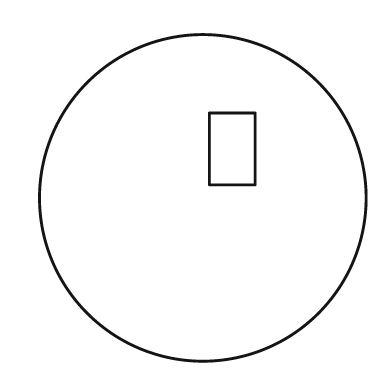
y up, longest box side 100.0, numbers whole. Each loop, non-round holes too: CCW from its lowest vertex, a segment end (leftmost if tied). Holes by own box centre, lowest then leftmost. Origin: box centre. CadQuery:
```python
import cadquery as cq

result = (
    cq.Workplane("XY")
    .moveTo(0.0, 0.0)
    .circle(50.0)
    .moveTo(2.0, 4.0)
    .lineTo(16.0, 4.0)
    .lineTo(16.0, 26.0)
    .lineTo(2.0, 26.0)
    .close()
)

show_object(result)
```